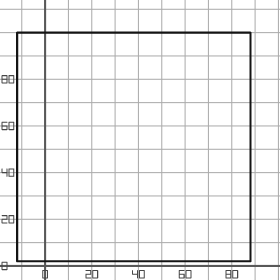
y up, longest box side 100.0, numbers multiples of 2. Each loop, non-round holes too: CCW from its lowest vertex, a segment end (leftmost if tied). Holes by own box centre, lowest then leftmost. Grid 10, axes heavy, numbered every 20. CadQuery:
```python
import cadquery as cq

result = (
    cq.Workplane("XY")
    .moveTo(-12.0, 2.0)
    .lineTo(88.0, 2.0)
    .lineTo(88.0, 100.0)
    .lineTo(-12.0, 100.0)
    .close()
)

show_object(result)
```